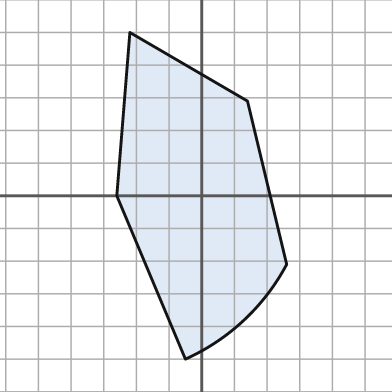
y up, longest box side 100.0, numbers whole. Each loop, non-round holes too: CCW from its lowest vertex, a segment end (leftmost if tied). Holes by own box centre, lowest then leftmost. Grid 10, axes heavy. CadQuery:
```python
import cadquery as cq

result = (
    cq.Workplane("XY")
    .moveTo(-5.0, -50.0)
    .threePointArc((13.0, -38.0), (26.0, -21.0))
    .lineTo(14.0, 29.0)
    .lineTo(-22.0, 50.0)
    .lineTo(-26.0, 0.0)
    .close()
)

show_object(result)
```